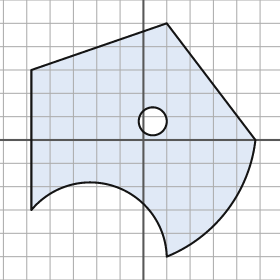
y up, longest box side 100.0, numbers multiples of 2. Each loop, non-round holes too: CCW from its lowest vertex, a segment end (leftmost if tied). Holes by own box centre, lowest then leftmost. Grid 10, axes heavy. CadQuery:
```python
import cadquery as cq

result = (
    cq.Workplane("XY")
    .moveTo(10.0, -50.0)
    .threePointArc((36.0, -30.0), (48.0, 0.0))
    .lineTo(10.0, 50.0)
    .lineTo(-48.0, 30.0)
    .lineTo(-48.0, -30.0)
    .threePointArc((-12.0, -20.0), (10.0, -50.0))
    .close()
    .moveTo(4.0, 8.0)
    .circle(6.0)
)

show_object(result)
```